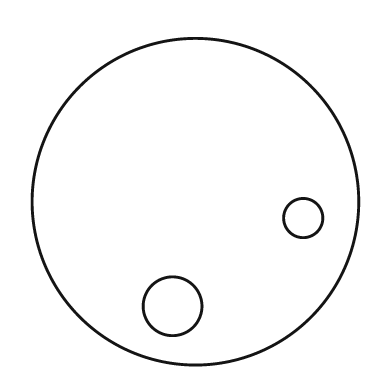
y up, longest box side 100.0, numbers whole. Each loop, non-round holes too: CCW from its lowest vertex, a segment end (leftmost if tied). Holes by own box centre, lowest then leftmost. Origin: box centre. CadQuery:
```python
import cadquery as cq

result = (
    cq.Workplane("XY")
    .moveTo(0.0, 0.0)
    .circle(50.0)
    .moveTo(-7.0, -32.0)
    .circle(9.0)
    .moveTo(33.0, -5.0)
    .circle(6.0)
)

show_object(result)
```